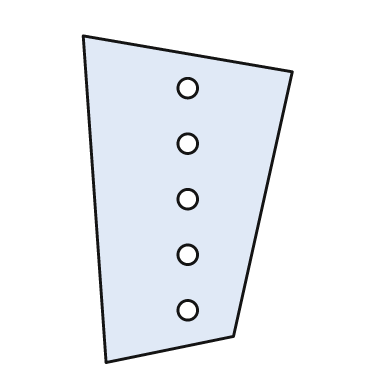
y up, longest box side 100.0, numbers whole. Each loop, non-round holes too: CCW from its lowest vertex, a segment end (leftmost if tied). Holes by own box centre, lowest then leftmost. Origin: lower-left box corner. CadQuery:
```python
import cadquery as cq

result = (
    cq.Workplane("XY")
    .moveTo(7.0, 0.0)
    .lineTo(46.0, 8.0)
    .lineTo(64.0, 89.0)
    .lineTo(0.0, 100.0)
    .close()
    .moveTo(32.0, 16.0)
    .circle(3.0)
    .moveTo(32.0, 33.0)
    .circle(3.0)
    .moveTo(32.0, 50.0)
    .circle(3.0)
    .moveTo(32.0, 67.0)
    .circle(3.0)
    .moveTo(32.0, 84.0)
    .circle(3.0)
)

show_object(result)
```